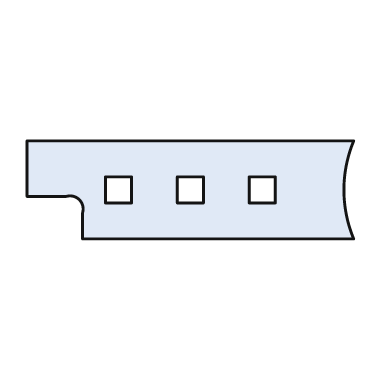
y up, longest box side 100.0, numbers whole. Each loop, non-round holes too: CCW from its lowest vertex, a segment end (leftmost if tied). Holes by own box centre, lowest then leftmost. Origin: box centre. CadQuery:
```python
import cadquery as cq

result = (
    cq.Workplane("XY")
    .moveTo(-33.0, -15.0)
    .lineTo(50.0, -15.0)
    .threePointArc((47.0, 0.0), (50.0, 15.0))
    .lineTo(-50.0, 15.0)
    .lineTo(-50.0, -2.0)
    .lineTo(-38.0, -2.0)
    .threePointArc((-34.0, -3.0), (-33.0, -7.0))
    .close()
    .moveTo(-26.0, -4.0)
    .lineTo(-18.0, -4.0)
    .lineTo(-18.0, 4.0)
    .lineTo(-26.0, 4.0)
    .close()
    .moveTo(-4.0, -4.0)
    .lineTo(4.0, -4.0)
    .lineTo(4.0, 4.0)
    .lineTo(-4.0, 4.0)
    .close()
    .moveTo(18.0, -4.0)
    .lineTo(26.0, -4.0)
    .lineTo(26.0, 4.0)
    .lineTo(18.0, 4.0)
    .close()
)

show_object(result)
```